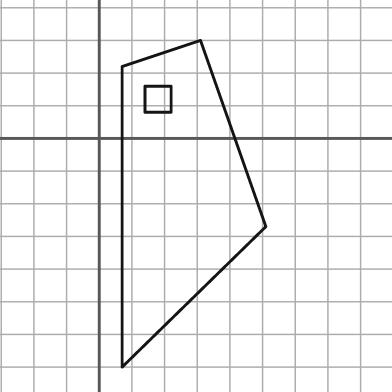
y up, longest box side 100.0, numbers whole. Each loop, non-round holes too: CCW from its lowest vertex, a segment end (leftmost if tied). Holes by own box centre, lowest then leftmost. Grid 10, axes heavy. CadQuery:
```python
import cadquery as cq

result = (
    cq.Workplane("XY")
    .moveTo(7.0, -70.0)
    .lineTo(51.0, -27.0)
    .lineTo(31.0, 30.0)
    .lineTo(7.0, 22.0)
    .close()
    .moveTo(14.0, 8.0)
    .lineTo(22.0, 8.0)
    .lineTo(22.0, 16.0)
    .lineTo(14.0, 16.0)
    .close()
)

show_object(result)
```